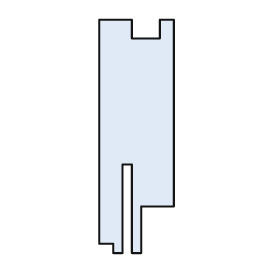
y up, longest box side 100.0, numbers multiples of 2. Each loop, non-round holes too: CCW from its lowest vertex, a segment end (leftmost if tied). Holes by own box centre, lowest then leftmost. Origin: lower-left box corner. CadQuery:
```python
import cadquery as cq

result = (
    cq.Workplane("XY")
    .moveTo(6.0, 0.0)
    .lineTo(10.0, 0.0)
    .lineTo(10.0, 38.0)
    .lineTo(14.0, 38.0)
    .lineTo(14.0, 0.0)
    .lineTo(18.0, 0.0)
    .lineTo(18.0, 20.0)
    .lineTo(32.0, 20.0)
    .lineTo(32.0, 100.0)
    .lineTo(26.0, 100.0)
    .lineTo(26.0, 92.0)
    .lineTo(14.0, 92.0)
    .lineTo(14.0, 100.0)
    .lineTo(0.0, 100.0)
    .lineTo(0.0, 4.0)
    .lineTo(6.0, 4.0)
    .close()
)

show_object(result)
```